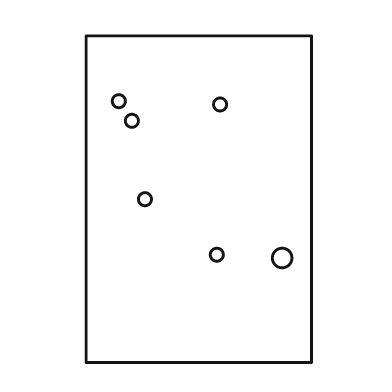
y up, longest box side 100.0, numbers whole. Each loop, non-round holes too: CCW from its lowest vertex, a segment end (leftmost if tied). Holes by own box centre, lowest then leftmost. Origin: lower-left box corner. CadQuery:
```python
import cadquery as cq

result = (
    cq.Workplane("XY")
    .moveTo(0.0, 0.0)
    .lineTo(69.0, 0.0)
    .lineTo(69.0, 100.0)
    .lineTo(0.0, 100.0)
    .close()
    .moveTo(60.0, 32.0)
    .circle(3.0)
    .moveTo(40.0, 33.0)
    .circle(2.0)
    .moveTo(18.0, 50.0)
    .circle(2.0)
    .moveTo(14.0, 74.0)
    .circle(2.0)
    .moveTo(41.0, 79.0)
    .circle(2.0)
    .moveTo(10.0, 80.0)
    .circle(2.0)
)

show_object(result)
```